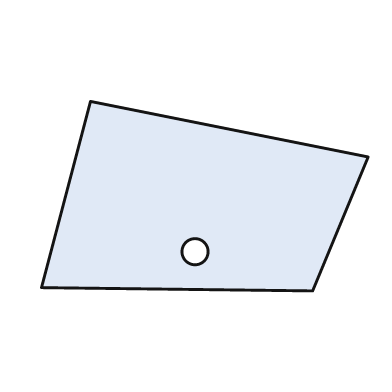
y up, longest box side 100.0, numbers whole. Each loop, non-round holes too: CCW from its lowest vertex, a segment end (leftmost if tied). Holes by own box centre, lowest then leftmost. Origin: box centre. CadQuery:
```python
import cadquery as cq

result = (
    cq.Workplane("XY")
    .moveTo(33.0, -29.0)
    .lineTo(50.0, 12.0)
    .lineTo(-35.0, 29.0)
    .lineTo(-50.0, -28.0)
    .close()
    .moveTo(-3.0, -17.0)
    .circle(4.0)
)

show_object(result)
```